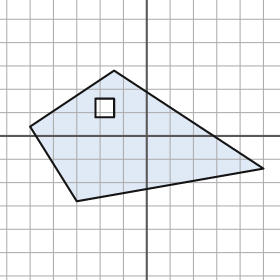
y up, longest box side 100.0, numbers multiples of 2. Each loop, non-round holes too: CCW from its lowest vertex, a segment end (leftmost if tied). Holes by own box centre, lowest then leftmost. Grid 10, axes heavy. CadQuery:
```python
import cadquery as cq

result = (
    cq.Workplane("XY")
    .moveTo(-30.0, -28.0)
    .lineTo(50.0, -14.0)
    .lineTo(-14.0, 28.0)
    .lineTo(-50.0, 4.0)
    .close()
    .moveTo(-22.0, 8.0)
    .lineTo(-14.0, 8.0)
    .lineTo(-14.0, 16.0)
    .lineTo(-22.0, 16.0)
    .close()
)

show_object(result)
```